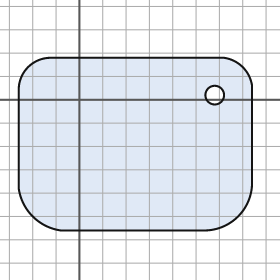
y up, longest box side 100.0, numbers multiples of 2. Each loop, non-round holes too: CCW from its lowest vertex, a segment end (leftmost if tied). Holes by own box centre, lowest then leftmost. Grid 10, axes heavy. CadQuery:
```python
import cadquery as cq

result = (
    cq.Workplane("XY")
    .moveTo(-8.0, -56.0)
    .lineTo(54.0, -56.0)
    .threePointArc((68.0, -50.0), (74.0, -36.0))
    .lineTo(74.0, 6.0)
    .threePointArc((70.0, 14.0), (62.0, 18.0))
    .lineTo(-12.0, 18.0)
    .threePointArc((-22.0, 14.0), (-26.0, 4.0))
    .lineTo(-26.0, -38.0)
    .threePointArc((-20.0, -50.0), (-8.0, -56.0))
    .close()
    .moveTo(58.0, 2.0)
    .circle(4.0)
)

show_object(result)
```